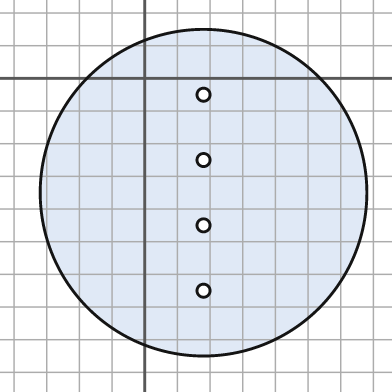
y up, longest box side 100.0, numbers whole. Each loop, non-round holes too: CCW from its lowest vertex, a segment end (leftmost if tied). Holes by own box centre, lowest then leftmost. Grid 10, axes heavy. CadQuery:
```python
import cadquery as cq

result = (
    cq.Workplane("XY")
    .moveTo(18.0, -35.0)
    .circle(50.0)
    .moveTo(18.0, -65.0)
    .circle(2.0)
    .moveTo(18.0, -45.0)
    .circle(2.0)
    .moveTo(18.0, -25.0)
    .circle(2.0)
    .moveTo(18.0, -5.0)
    .circle(2.0)
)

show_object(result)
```